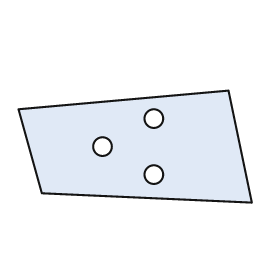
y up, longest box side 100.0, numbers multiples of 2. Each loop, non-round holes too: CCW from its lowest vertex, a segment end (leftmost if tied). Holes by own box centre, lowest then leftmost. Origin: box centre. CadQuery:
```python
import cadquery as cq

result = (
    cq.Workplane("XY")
    .moveTo(50.0, -24.0)
    .lineTo(40.0, 24.0)
    .lineTo(-50.0, 16.0)
    .lineTo(-40.0, -20.0)
    .close()
    .moveTo(8.0, -12.0)
    .circle(4.0)
    .moveTo(-14.0, 0.0)
    .circle(4.0)
    .moveTo(8.0, 12.0)
    .circle(4.0)
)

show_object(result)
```